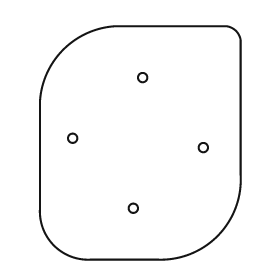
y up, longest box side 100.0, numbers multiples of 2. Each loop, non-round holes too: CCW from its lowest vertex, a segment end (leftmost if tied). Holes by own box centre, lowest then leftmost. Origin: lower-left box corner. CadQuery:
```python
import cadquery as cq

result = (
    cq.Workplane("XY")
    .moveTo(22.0, 0.0)
    .lineTo(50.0, 0.0)
    .threePointArc((76.0, 10.0), (86.0, 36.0))
    .lineTo(86.0, 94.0)
    .threePointArc((84.0, 98.0), (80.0, 100.0))
    .lineTo(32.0, 100.0)
    .threePointArc((10.0, 90.0), (0.0, 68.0))
    .lineTo(0.0, 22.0)
    .threePointArc((6.0, 6.0), (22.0, 0.0))
    .close()
    .moveTo(40.0, 22.0)
    .circle(2.0)
    .moveTo(70.0, 48.0)
    .circle(2.0)
    .moveTo(14.0, 52.0)
    .circle(2.0)
    .moveTo(44.0, 78.0)
    .circle(2.0)
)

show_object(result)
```